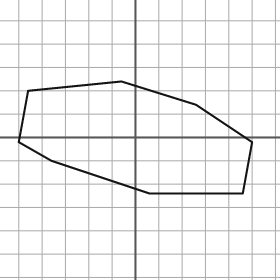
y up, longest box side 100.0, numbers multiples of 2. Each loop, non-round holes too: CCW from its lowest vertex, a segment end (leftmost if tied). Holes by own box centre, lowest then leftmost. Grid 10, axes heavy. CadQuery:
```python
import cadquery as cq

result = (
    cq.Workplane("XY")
    .moveTo(6.0, -24.0)
    .lineTo(46.0, -24.0)
    .lineTo(50.0, -2.0)
    .lineTo(26.0, 14.0)
    .lineTo(-6.0, 24.0)
    .lineTo(-46.0, 20.0)
    .lineTo(-50.0, -2.0)
    .lineTo(-36.0, -10.0)
    .close()
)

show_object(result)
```